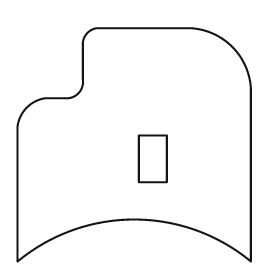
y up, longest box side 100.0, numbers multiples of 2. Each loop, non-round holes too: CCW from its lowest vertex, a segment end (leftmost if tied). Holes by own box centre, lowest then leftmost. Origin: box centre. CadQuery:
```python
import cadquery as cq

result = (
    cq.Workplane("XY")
    .moveTo(-50.0, -50.0)
    .threePointArc((0.0, -32.0), (50.0, -50.0))
    .lineTo(50.0, 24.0)
    .threePointArc((42.0, 42.0), (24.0, 50.0))
    .lineTo(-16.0, 50.0)
    .threePointArc((-20.0, 48.0), (-22.0, 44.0))
    .lineTo(-22.0, 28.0)
    .threePointArc((-24.0, 22.0), (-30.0, 20.0))
    .lineTo(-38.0, 20.0)
    .threePointArc((-46.0, 16.0), (-50.0, 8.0))
    .close()
    .moveTo(2.0, -16.0)
    .lineTo(14.0, -16.0)
    .lineTo(14.0, 4.0)
    .lineTo(2.0, 4.0)
    .close()
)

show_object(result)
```